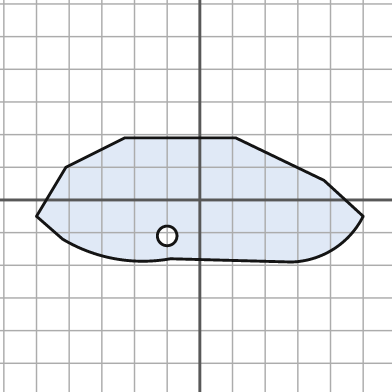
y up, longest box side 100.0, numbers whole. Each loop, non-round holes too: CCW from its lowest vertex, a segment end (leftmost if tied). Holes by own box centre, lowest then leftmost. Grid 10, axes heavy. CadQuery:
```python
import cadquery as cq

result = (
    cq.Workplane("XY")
    .moveTo(28.0, -19.0)
    .threePointArc((41.0, -15.0), (50.0, -5.0))
    .lineTo(38.0, 6.0)
    .lineTo(11.0, 19.0)
    .lineTo(-23.0, 19.0)
    .lineTo(-41.0, 10.0)
    .lineTo(-50.0, -5.0)
    .lineTo(-42.0, -12.0)
    .threePointArc((-26.0, -18.0), (-9.0, -18.0))
    .close()
    .moveTo(-10.0, -11.0)
    .circle(3.0)
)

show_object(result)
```